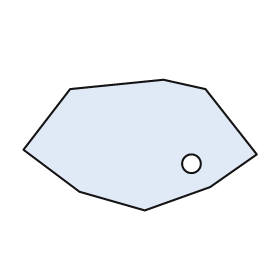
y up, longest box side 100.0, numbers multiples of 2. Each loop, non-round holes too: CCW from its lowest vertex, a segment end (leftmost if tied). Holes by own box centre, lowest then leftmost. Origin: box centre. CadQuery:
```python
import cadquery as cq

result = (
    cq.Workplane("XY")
    .moveTo(2.0, -28.0)
    .lineTo(30.0, -18.0)
    .lineTo(50.0, -4.0)
    .lineTo(28.0, 24.0)
    .lineTo(10.0, 28.0)
    .lineTo(-30.0, 24.0)
    .lineTo(-50.0, -2.0)
    .lineTo(-26.0, -20.0)
    .close()
    .moveTo(22.0, -8.0)
    .circle(4.0)
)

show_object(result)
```